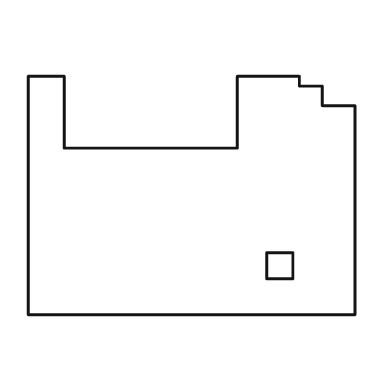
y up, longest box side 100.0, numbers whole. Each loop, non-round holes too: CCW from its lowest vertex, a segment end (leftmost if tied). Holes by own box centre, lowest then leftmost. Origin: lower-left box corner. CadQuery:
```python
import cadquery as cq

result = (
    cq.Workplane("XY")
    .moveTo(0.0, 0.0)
    .lineTo(100.0, 0.0)
    .lineTo(100.0, 64.0)
    .lineTo(90.0, 64.0)
    .lineTo(90.0, 70.0)
    .lineTo(83.0, 70.0)
    .lineTo(83.0, 73.0)
    .lineTo(64.0, 73.0)
    .lineTo(64.0, 51.0)
    .lineTo(11.0, 51.0)
    .lineTo(11.0, 73.0)
    .lineTo(0.0, 73.0)
    .close()
    .moveTo(73.0, 11.0)
    .lineTo(81.0, 11.0)
    .lineTo(81.0, 19.0)
    .lineTo(73.0, 19.0)
    .close()
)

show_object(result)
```